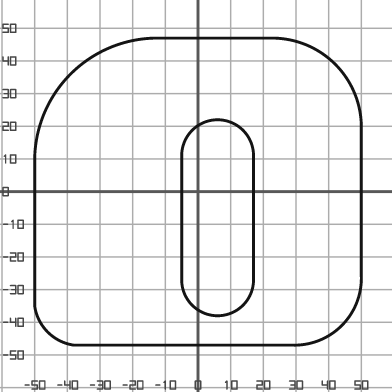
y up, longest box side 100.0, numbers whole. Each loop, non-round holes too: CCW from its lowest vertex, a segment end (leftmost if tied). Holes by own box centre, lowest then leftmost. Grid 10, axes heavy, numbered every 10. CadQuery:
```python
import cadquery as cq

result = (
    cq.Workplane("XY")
    .moveTo(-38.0, -47.0)
    .lineTo(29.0, -47.0)
    .threePointArc((44.0, -41.0), (50.0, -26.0))
    .lineTo(50.0, 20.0)
    .threePointArc((42.0, 39.0), (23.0, 47.0))
    .lineTo(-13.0, 47.0)
    .threePointArc((-39.0, 36.0), (-50.0, 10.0))
    .lineTo(-50.0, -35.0)
    .threePointArc((-46.0, -43.0), (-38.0, -47.0))
    .close()
    .moveTo(-5.0, -27.0)
    .threePointArc((6.0, -38.0), (17.0, -27.0))
    .lineTo(17.0, 11.0)
    .threePointArc((6.0, 22.0), (-5.0, 11.0))
    .close()
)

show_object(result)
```